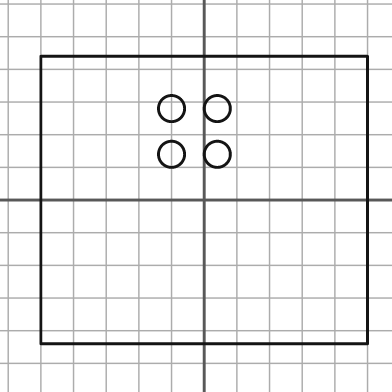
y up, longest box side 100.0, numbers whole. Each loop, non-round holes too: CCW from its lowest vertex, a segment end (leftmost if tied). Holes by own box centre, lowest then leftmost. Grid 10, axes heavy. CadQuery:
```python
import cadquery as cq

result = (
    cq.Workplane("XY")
    .moveTo(-50.0, -44.0)
    .lineTo(50.0, -44.0)
    .lineTo(50.0, 44.0)
    .lineTo(-50.0, 44.0)
    .close()
    .moveTo(-10.0, 14.0)
    .circle(4.0)
    .moveTo(4.0, 14.0)
    .circle(4.0)
    .moveTo(-10.0, 28.0)
    .circle(4.0)
    .moveTo(4.0, 28.0)
    .circle(4.0)
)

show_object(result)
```